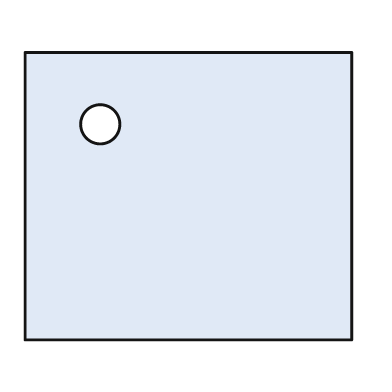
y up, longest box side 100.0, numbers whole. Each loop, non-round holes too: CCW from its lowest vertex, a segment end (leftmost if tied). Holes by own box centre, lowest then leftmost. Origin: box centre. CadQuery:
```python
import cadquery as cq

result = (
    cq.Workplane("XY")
    .moveTo(-50.0, -44.0)
    .lineTo(50.0, -44.0)
    .lineTo(50.0, 44.0)
    .lineTo(-50.0, 44.0)
    .close()
    .moveTo(-27.0, 22.0)
    .circle(6.0)
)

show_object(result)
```